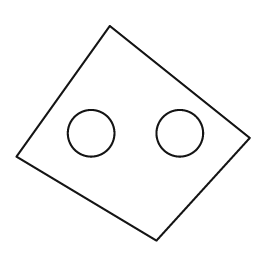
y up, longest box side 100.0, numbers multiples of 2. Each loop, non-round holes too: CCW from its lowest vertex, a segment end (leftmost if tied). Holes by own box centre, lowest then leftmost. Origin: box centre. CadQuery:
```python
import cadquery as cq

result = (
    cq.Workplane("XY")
    .moveTo(10.0, -46.0)
    .lineTo(50.0, -2.0)
    .lineTo(-10.0, 46.0)
    .lineTo(-50.0, -10.0)
    .close()
    .moveTo(-18.0, 0.0)
    .circle(10.0)
    .moveTo(20.0, 0.0)
    .circle(10.0)
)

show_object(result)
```